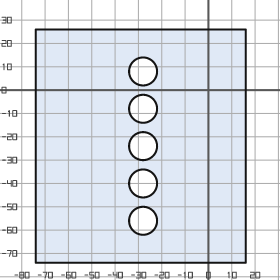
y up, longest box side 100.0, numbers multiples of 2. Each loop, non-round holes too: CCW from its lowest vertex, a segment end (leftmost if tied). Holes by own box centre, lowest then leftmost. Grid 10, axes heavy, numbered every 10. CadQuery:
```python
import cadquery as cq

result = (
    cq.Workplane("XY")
    .moveTo(-74.0, -74.0)
    .lineTo(16.0, -74.0)
    .lineTo(16.0, 26.0)
    .lineTo(-74.0, 26.0)
    .close()
    .moveTo(-28.0, -56.0)
    .circle(6.0)
    .moveTo(-28.0, -40.0)
    .circle(6.0)
    .moveTo(-28.0, -24.0)
    .circle(6.0)
    .moveTo(-28.0, -8.0)
    .circle(6.0)
    .moveTo(-28.0, 8.0)
    .circle(6.0)
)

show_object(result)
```